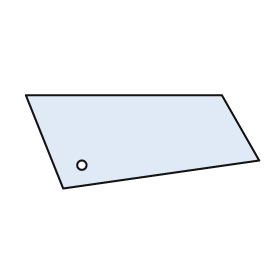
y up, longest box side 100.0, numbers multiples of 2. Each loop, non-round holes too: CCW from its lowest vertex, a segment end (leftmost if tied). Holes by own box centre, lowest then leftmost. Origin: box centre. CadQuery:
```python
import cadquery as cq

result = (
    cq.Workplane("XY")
    .moveTo(-34.0, -20.0)
    .lineTo(50.0, -8.0)
    .lineTo(34.0, 20.0)
    .lineTo(-50.0, 20.0)
    .close()
    .moveTo(-26.0, -10.0)
    .circle(2.0)
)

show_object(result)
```